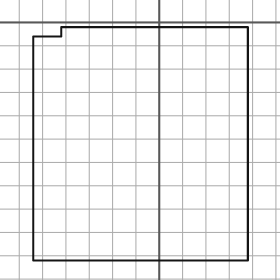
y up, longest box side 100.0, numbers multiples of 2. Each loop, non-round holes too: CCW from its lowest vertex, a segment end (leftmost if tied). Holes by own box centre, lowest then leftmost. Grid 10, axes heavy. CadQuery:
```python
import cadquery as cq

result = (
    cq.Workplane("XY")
    .moveTo(-54.0, -102.0)
    .lineTo(38.0, -102.0)
    .lineTo(38.0, -2.0)
    .lineTo(-42.0, -2.0)
    .lineTo(-42.0, -6.0)
    .lineTo(-54.0, -6.0)
    .close()
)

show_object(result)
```